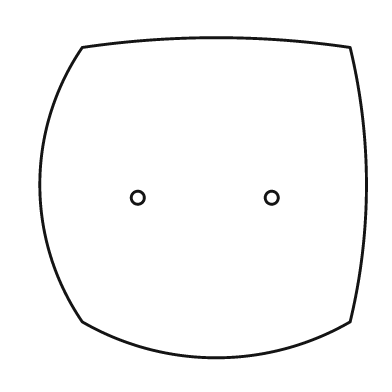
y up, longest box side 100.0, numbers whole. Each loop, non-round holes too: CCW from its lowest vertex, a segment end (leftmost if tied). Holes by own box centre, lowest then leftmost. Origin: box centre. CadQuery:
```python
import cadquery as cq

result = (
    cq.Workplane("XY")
    .moveTo(-37.0, -38.0)
    .threePointArc((4.0, -49.0), (45.0, -38.0))
    .threePointArc((50.0, 4.0), (45.0, 46.0))
    .threePointArc((4.0, 49.0), (-37.0, 46.0))
    .threePointArc((-50.0, 4.0), (-37.0, -38.0))
    .close()
    .moveTo(-20.0, 0.0)
    .circle(2.0)
    .moveTo(21.0, 0.0)
    .circle(2.0)
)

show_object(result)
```